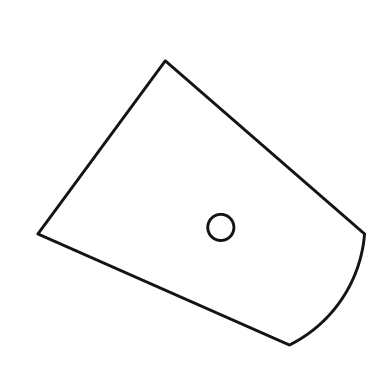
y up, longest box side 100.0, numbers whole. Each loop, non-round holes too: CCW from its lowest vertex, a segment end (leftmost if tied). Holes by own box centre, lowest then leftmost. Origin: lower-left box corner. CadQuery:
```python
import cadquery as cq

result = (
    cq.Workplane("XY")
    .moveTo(77.0, 0.0)
    .threePointArc((93.0, 14.0), (100.0, 34.0))
    .lineTo(39.0, 87.0)
    .lineTo(0.0, 34.0)
    .close()
    .moveTo(56.0, 36.0)
    .circle(4.0)
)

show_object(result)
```